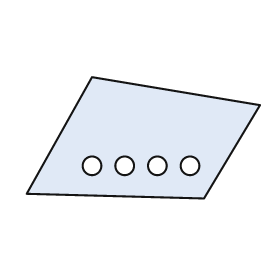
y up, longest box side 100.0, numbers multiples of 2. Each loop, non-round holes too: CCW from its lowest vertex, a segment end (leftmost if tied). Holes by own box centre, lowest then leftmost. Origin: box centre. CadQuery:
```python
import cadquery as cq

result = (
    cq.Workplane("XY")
    .moveTo(26.0, -26.0)
    .lineTo(50.0, 14.0)
    .lineTo(-22.0, 26.0)
    .lineTo(-50.0, -24.0)
    .close()
    .moveTo(-22.0, -12.0)
    .circle(4.0)
    .moveTo(-8.0, -12.0)
    .circle(4.0)
    .moveTo(6.0, -12.0)
    .circle(4.0)
    .moveTo(20.0, -12.0)
    .circle(4.0)
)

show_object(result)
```